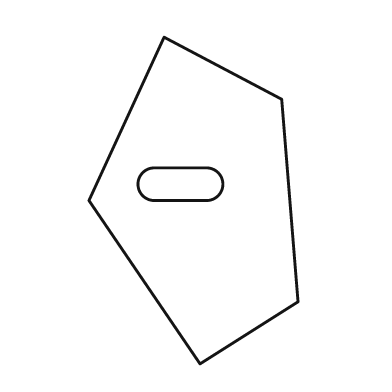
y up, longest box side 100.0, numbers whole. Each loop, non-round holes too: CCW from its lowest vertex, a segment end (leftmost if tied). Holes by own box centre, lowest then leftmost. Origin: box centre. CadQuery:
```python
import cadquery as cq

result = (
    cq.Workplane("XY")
    .moveTo(2.0, -50.0)
    .lineTo(32.0, -31.0)
    .lineTo(27.0, 31.0)
    .lineTo(-9.0, 50.0)
    .lineTo(-32.0, 0.0)
    .close()
    .moveTo(-12.0, 0.0)
    .lineTo(4.0, 0.0)
    .threePointArc((9.0, 5.0), (4.0, 10.0))
    .lineTo(-12.0, 10.0)
    .threePointArc((-17.0, 5.0), (-12.0, 0.0))
    .close()
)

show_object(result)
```